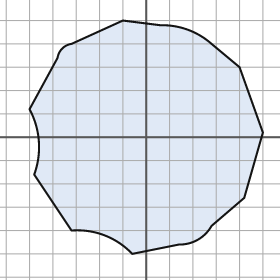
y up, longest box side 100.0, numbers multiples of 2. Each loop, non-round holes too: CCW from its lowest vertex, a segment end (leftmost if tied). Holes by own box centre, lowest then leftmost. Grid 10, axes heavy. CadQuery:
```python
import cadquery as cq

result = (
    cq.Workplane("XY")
    .moveTo(-6.0, -50.0)
    .lineTo(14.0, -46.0)
    .threePointArc((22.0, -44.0), (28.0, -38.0))
    .lineTo(42.0, -26.0)
    .lineTo(50.0, 2.0)
    .lineTo(40.0, 30.0)
    .lineTo(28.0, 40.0)
    .threePointArc((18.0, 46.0), (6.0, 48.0))
    .lineTo(-10.0, 50.0)
    .lineTo(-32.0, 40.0)
    .threePointArc((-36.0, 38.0), (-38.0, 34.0))
    .lineTo(-50.0, 12.0)
    .threePointArc((-46.0, -2.0), (-48.0, -16.0))
    .lineTo(-32.0, -40.0)
    .threePointArc((-18.0, -42.0), (-6.0, -50.0))
    .close()
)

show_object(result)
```